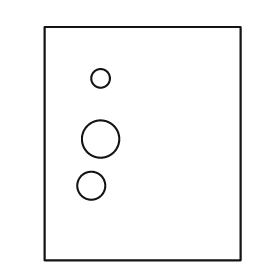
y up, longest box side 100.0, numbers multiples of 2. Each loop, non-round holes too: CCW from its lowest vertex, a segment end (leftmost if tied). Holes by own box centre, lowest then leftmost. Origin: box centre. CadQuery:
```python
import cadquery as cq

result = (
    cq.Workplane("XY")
    .moveTo(-42.0, -50.0)
    .lineTo(42.0, -50.0)
    .lineTo(42.0, 50.0)
    .lineTo(-42.0, 50.0)
    .close()
    .moveTo(-22.0, -18.0)
    .circle(6.0)
    .moveTo(-18.0, 2.0)
    .circle(8.0)
    .moveTo(-18.0, 28.0)
    .circle(4.0)
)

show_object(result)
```